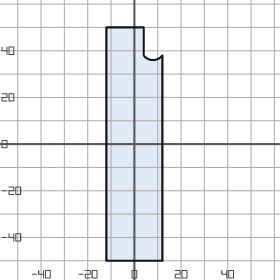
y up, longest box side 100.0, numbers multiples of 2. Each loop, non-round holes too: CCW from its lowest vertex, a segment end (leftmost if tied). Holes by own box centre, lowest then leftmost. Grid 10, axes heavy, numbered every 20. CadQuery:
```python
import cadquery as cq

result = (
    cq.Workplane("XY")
    .moveTo(-12.0, -50.0)
    .lineTo(12.0, -50.0)
    .lineTo(12.0, 38.0)
    .threePointArc((8.0, 36.0), (4.0, 38.0))
    .lineTo(4.0, 50.0)
    .lineTo(-12.0, 50.0)
    .close()
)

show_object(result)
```